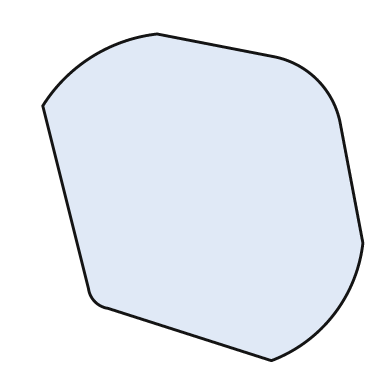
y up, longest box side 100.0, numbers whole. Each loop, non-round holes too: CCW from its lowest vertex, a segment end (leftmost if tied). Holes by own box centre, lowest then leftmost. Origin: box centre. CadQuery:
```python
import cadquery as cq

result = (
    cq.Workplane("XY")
    .moveTo(21.0, -50.0)
    .threePointArc((40.0, -36.0), (49.0, -14.0))
    .lineTo(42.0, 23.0)
    .threePointArc((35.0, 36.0), (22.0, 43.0))
    .lineTo(-14.0, 50.0)
    .threePointArc((-34.0, 43.0), (-49.0, 28.0))
    .lineTo(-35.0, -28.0)
    .threePointArc((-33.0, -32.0), (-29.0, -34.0))
    .close()
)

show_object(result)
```